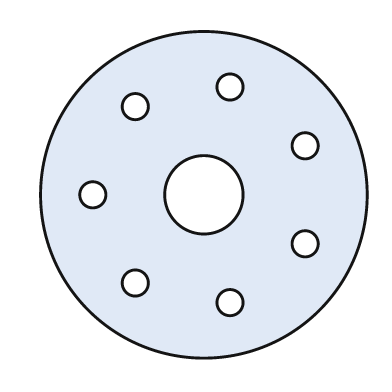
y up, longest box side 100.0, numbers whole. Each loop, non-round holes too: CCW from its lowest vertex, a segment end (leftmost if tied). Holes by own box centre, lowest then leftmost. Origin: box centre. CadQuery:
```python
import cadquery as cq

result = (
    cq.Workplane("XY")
    .moveTo(0.0, 0.0)
    .circle(50.0)
    .moveTo(8.0, -33.0)
    .circle(4.0)
    .moveTo(-21.0, -27.0)
    .circle(4.0)
    .moveTo(31.0, -15.0)
    .circle(4.0)
    .moveTo(-34.0, 0.0)
    .circle(4.0)
    .moveTo(0.0, 0.0)
    .circle(12.0)
    .moveTo(31.0, 15.0)
    .circle(4.0)
    .moveTo(-21.0, 27.0)
    .circle(4.0)
    .moveTo(8.0, 33.0)
    .circle(4.0)
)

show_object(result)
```